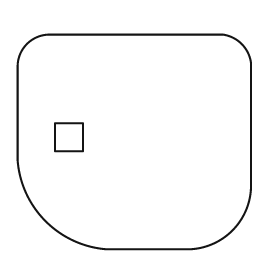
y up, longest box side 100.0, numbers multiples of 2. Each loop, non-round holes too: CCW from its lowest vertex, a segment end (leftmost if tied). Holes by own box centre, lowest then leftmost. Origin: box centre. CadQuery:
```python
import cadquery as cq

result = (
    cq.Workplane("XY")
    .moveTo(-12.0, -46.0)
    .lineTo(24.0, -46.0)
    .threePointArc((42.0, -38.0), (50.0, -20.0))
    .lineTo(50.0, 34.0)
    .threePointArc((46.0, 42.0), (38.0, 46.0))
    .lineTo(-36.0, 46.0)
    .threePointArc((-46.0, 42.0), (-50.0, 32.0))
    .lineTo(-50.0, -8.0)
    .threePointArc((-38.0, -34.0), (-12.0, -46.0))
    .close()
    .moveTo(-34.0, -4.0)
    .lineTo(-22.0, -4.0)
    .lineTo(-22.0, 8.0)
    .lineTo(-34.0, 8.0)
    .close()
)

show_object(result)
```